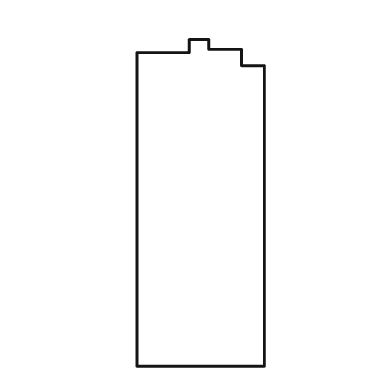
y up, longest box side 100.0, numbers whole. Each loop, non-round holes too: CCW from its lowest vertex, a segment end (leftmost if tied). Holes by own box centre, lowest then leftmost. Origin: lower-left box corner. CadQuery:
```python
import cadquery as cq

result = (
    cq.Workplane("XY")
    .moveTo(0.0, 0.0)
    .lineTo(39.0, 0.0)
    .lineTo(39.0, 92.0)
    .lineTo(32.0, 92.0)
    .lineTo(32.0, 97.0)
    .lineTo(22.0, 97.0)
    .lineTo(22.0, 100.0)
    .lineTo(16.0, 100.0)
    .lineTo(16.0, 96.0)
    .lineTo(0.0, 96.0)
    .close()
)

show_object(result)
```